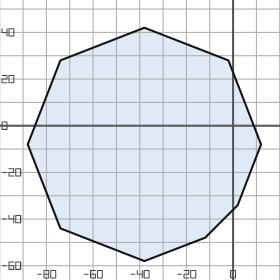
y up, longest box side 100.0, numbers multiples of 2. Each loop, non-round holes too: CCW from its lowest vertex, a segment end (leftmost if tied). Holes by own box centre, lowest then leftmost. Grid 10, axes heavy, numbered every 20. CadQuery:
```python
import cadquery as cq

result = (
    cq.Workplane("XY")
    .moveTo(-38.0, -58.0)
    .lineTo(-12.0, -48.0)
    .lineTo(2.0, -34.0)
    .lineTo(12.0, -8.0)
    .lineTo(-2.0, 28.0)
    .lineTo(-38.0, 42.0)
    .lineTo(-74.0, 28.0)
    .lineTo(-88.0, -8.0)
    .lineTo(-74.0, -44.0)
    .close()
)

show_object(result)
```